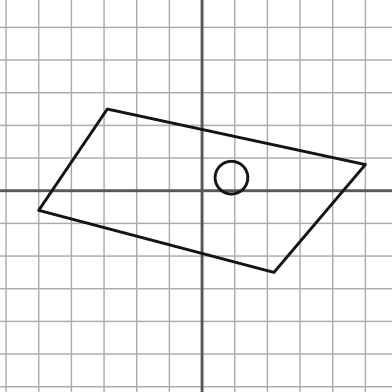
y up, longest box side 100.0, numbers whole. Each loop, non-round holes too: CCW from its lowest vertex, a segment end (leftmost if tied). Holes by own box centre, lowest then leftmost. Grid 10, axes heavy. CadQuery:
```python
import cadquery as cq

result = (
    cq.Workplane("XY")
    .moveTo(22.0, -25.0)
    .lineTo(50.0, 8.0)
    .lineTo(-29.0, 25.0)
    .lineTo(-50.0, -6.0)
    .close()
    .moveTo(9.0, 4.0)
    .circle(5.0)
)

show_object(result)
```